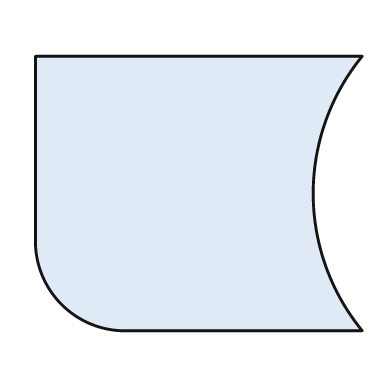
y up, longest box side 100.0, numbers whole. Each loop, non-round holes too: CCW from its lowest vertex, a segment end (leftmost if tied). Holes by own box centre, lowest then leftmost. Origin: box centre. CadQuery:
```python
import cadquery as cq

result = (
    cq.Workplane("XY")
    .moveTo(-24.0, -42.0)
    .lineTo(50.0, -42.0)
    .threePointArc((35.0, 0.0), (50.0, 42.0))
    .lineTo(-50.0, 42.0)
    .lineTo(-50.0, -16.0)
    .threePointArc((-42.0, -34.0), (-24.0, -42.0))
    .close()
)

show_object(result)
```